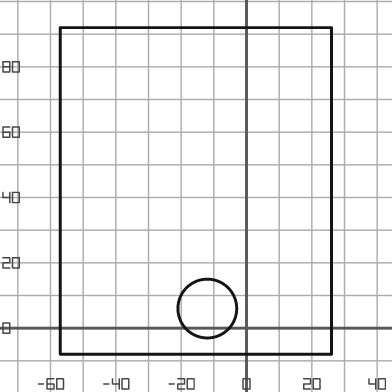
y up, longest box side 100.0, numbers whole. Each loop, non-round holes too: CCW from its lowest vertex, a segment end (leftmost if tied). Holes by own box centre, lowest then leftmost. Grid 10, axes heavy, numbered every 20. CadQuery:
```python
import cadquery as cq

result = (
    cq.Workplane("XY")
    .moveTo(-57.0, -8.0)
    .lineTo(26.0, -8.0)
    .lineTo(26.0, 92.0)
    .lineTo(-57.0, 92.0)
    .close()
    .moveTo(-12.0, 6.0)
    .circle(9.0)
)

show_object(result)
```